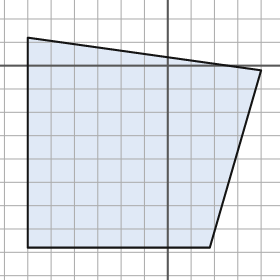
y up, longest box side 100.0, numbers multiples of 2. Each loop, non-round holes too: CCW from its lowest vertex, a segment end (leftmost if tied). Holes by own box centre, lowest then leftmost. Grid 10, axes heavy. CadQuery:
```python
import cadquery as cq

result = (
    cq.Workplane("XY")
    .moveTo(-60.0, -78.0)
    .lineTo(18.0, -78.0)
    .lineTo(40.0, -2.0)
    .lineTo(-60.0, 12.0)
    .close()
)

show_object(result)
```